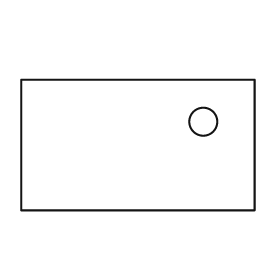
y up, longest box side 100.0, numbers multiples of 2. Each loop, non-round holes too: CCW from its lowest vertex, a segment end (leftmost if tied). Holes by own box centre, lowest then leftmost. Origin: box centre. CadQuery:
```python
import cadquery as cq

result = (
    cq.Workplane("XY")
    .moveTo(-50.0, -28.0)
    .lineTo(50.0, -28.0)
    .lineTo(50.0, 28.0)
    .lineTo(-50.0, 28.0)
    .close()
    .moveTo(28.0, 10.0)
    .circle(6.0)
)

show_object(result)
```